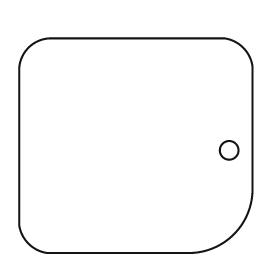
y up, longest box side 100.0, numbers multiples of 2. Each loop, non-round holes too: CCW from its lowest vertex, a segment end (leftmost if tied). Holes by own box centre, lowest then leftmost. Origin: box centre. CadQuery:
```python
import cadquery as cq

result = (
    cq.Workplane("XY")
    .moveTo(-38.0, -46.0)
    .lineTo(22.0, -46.0)
    .threePointArc((42.0, -38.0), (50.0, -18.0))
    .lineTo(50.0, 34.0)
    .threePointArc((46.0, 42.0), (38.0, 46.0))
    .lineTo(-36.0, 46.0)
    .threePointArc((-46.0, 42.0), (-50.0, 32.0))
    .lineTo(-50.0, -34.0)
    .threePointArc((-46.0, -42.0), (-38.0, -46.0))
    .close()
    .moveTo(40.0, -2.0)
    .circle(4.0)
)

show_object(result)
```